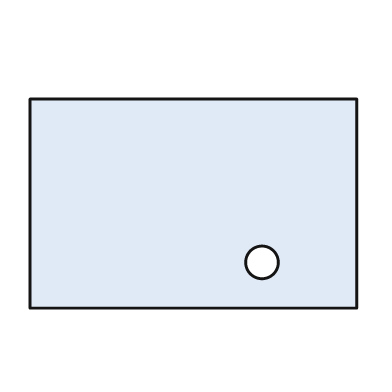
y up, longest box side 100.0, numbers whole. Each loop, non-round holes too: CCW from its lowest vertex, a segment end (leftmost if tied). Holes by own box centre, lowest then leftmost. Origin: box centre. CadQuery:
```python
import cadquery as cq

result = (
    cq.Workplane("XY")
    .moveTo(-50.0, -32.0)
    .lineTo(50.0, -32.0)
    .lineTo(50.0, 32.0)
    .lineTo(-50.0, 32.0)
    .close()
    .moveTo(21.0, -18.0)
    .circle(5.0)
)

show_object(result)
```